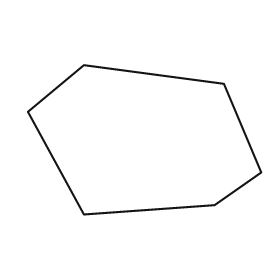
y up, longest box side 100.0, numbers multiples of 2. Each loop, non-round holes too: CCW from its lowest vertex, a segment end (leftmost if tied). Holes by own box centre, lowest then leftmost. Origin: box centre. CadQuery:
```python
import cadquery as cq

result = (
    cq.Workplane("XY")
    .moveTo(-26.0, -32.0)
    .lineTo(30.0, -28.0)
    .lineTo(50.0, -14.0)
    .lineTo(34.0, 24.0)
    .lineTo(-26.0, 32.0)
    .lineTo(-50.0, 12.0)
    .close()
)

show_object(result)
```